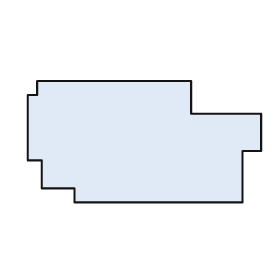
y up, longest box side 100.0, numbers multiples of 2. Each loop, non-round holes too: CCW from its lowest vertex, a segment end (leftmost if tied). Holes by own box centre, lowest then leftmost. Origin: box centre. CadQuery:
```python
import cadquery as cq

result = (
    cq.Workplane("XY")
    .moveTo(-30.0, -26.0)
    .lineTo(42.0, -26.0)
    .lineTo(42.0, -4.0)
    .lineTo(50.0, -4.0)
    .lineTo(50.0, 12.0)
    .lineTo(20.0, 12.0)
    .lineTo(20.0, 26.0)
    .lineTo(-46.0, 26.0)
    .lineTo(-46.0, 20.0)
    .lineTo(-50.0, 20.0)
    .lineTo(-50.0, -8.0)
    .lineTo(-44.0, -8.0)
    .lineTo(-44.0, -20.0)
    .lineTo(-30.0, -20.0)
    .close()
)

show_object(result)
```